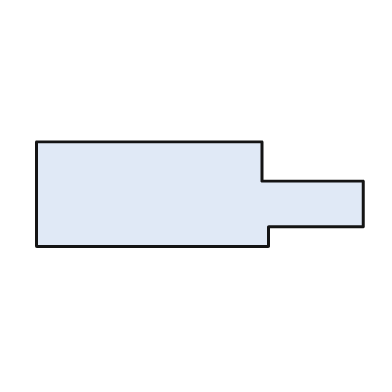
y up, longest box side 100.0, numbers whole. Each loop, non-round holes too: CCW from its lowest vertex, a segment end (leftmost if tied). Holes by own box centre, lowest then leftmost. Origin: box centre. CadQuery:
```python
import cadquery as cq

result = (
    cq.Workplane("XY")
    .moveTo(-50.0, -16.0)
    .lineTo(21.0, -16.0)
    .lineTo(21.0, -10.0)
    .lineTo(50.0, -10.0)
    .lineTo(50.0, 4.0)
    .lineTo(19.0, 4.0)
    .lineTo(19.0, 16.0)
    .lineTo(-50.0, 16.0)
    .close()
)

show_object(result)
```